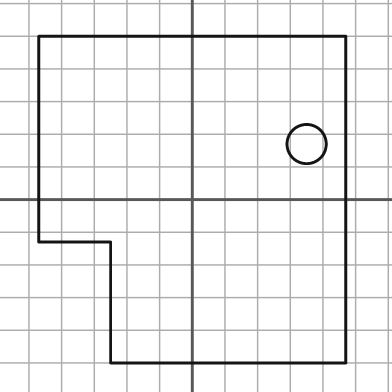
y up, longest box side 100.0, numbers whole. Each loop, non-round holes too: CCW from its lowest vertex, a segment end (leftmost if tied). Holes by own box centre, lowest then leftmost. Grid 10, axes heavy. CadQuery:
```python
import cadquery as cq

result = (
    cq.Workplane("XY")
    .moveTo(-25.0, -50.0)
    .lineTo(47.0, -50.0)
    .lineTo(47.0, 50.0)
    .lineTo(-47.0, 50.0)
    .lineTo(-47.0, -13.0)
    .lineTo(-25.0, -13.0)
    .close()
    .moveTo(35.0, 17.0)
    .circle(6.0)
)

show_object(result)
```